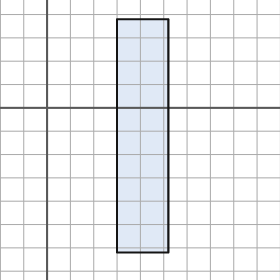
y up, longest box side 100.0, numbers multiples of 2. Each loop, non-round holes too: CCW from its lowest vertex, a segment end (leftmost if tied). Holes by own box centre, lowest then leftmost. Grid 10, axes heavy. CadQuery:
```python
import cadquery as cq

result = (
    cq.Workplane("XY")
    .moveTo(30.0, -62.0)
    .lineTo(52.0, -62.0)
    .lineTo(52.0, 38.0)
    .lineTo(30.0, 38.0)
    .close()
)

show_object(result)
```